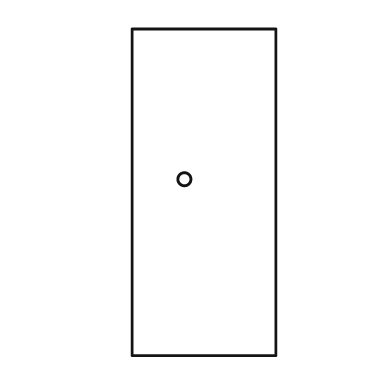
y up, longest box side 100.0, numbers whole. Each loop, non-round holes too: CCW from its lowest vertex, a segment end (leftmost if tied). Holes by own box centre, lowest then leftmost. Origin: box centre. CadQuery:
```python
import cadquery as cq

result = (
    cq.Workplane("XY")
    .moveTo(-22.0, -50.0)
    .lineTo(22.0, -50.0)
    .lineTo(22.0, 50.0)
    .lineTo(-22.0, 50.0)
    .close()
    .moveTo(-6.0, 4.0)
    .circle(2.0)
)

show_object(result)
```